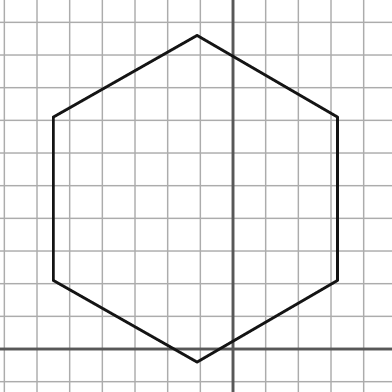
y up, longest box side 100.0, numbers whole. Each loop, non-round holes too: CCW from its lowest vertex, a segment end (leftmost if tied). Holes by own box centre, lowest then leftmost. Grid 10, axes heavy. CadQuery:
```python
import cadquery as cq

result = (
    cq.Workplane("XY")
    .moveTo(-11.0, -4.0)
    .lineTo(32.0, 21.0)
    .lineTo(32.0, 71.0)
    .lineTo(-11.0, 96.0)
    .lineTo(-55.0, 71.0)
    .lineTo(-55.0, 21.0)
    .close()
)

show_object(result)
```